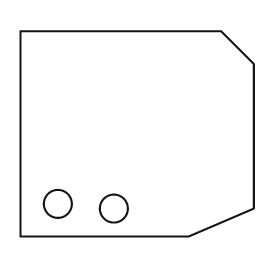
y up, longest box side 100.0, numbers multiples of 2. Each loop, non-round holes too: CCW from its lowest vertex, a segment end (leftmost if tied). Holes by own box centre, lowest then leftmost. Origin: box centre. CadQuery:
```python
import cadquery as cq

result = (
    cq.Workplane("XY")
    .moveTo(-50.0, -44.0)
    .lineTo(22.0, -44.0)
    .lineTo(50.0, -32.0)
    .lineTo(50.0, 30.0)
    .lineTo(36.0, 44.0)
    .lineTo(-50.0, 44.0)
    .close()
    .moveTo(-10.0, -32.0)
    .circle(6.0)
    .moveTo(-34.0, -30.0)
    .circle(6.0)
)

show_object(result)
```